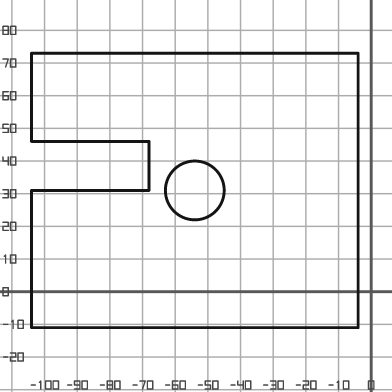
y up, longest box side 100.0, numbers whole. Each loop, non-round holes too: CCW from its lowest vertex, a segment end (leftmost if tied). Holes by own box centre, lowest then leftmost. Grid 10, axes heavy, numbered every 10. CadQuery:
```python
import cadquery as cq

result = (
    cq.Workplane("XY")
    .moveTo(-104.0, -11.0)
    .lineTo(-4.0, -11.0)
    .lineTo(-4.0, 73.0)
    .lineTo(-104.0, 73.0)
    .lineTo(-104.0, 46.0)
    .lineTo(-68.0, 46.0)
    .lineTo(-68.0, 31.0)
    .lineTo(-104.0, 31.0)
    .close()
    .moveTo(-54.0, 31.0)
    .circle(9.0)
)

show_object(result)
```